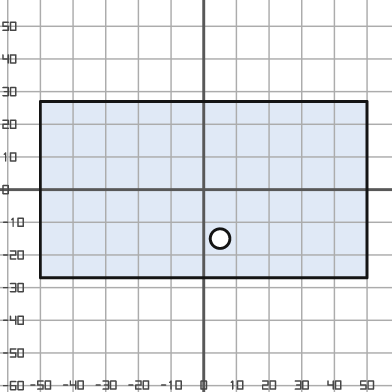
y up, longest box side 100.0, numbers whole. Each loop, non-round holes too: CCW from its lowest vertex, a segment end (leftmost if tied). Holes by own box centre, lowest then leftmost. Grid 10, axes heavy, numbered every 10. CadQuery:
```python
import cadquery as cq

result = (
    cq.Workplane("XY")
    .moveTo(-50.0, -27.0)
    .lineTo(50.0, -27.0)
    .lineTo(50.0, 27.0)
    .lineTo(-50.0, 27.0)
    .close()
    .moveTo(5.0, -15.0)
    .circle(3.0)
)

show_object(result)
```